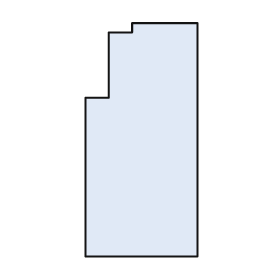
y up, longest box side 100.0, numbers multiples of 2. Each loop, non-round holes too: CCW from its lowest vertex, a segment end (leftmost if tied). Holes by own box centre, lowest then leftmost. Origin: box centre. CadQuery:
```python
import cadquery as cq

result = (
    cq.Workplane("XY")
    .moveTo(-24.0, -50.0)
    .lineTo(24.0, -50.0)
    .lineTo(24.0, 50.0)
    .lineTo(-4.0, 50.0)
    .lineTo(-4.0, 46.0)
    .lineTo(-14.0, 46.0)
    .lineTo(-14.0, 18.0)
    .lineTo(-24.0, 18.0)
    .close()
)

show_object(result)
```